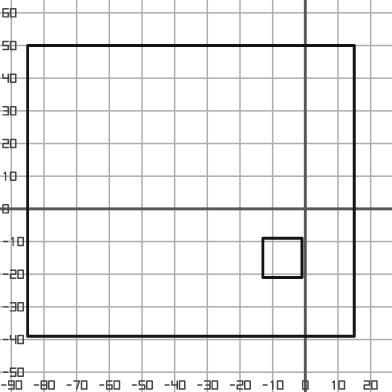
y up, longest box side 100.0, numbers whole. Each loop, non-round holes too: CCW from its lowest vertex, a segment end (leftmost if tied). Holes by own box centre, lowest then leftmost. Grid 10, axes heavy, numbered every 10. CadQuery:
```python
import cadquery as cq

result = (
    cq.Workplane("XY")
    .moveTo(-85.0, -39.0)
    .lineTo(15.0, -39.0)
    .lineTo(15.0, 50.0)
    .lineTo(-85.0, 50.0)
    .close()
    .moveTo(-13.0, -21.0)
    .lineTo(-1.0, -21.0)
    .lineTo(-1.0, -9.0)
    .lineTo(-13.0, -9.0)
    .close()
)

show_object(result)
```